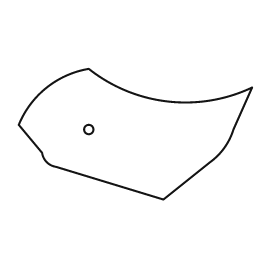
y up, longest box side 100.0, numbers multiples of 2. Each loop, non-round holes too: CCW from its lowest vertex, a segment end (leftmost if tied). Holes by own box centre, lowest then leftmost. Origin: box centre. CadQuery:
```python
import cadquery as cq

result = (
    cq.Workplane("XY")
    .moveTo(12.0, -28.0)
    .lineTo(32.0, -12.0)
    .threePointArc((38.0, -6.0), (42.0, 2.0))
    .lineTo(50.0, 20.0)
    .threePointArc((14.0, 14.0), (-20.0, 28.0))
    .threePointArc((-38.0, 20.0), (-50.0, 4.0))
    .lineTo(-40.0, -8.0)
    .threePointArc((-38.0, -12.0), (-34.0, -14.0))
    .close()
    .moveTo(-20.0, 2.0)
    .circle(2.0)
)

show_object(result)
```